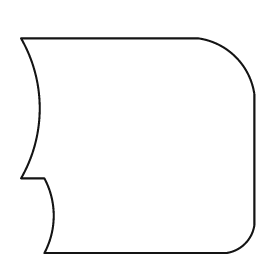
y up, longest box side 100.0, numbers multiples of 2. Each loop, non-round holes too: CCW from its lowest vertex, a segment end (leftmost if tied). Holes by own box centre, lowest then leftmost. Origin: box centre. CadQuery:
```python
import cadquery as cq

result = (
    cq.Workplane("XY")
    .moveTo(-40.0, -46.0)
    .lineTo(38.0, -46.0)
    .threePointArc((46.0, -42.0), (50.0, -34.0))
    .lineTo(50.0, 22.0)
    .threePointArc((42.0, 38.0), (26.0, 46.0))
    .lineTo(-50.0, 46.0)
    .threePointArc((-42.0, 16.0), (-50.0, -14.0))
    .lineTo(-40.0, -14.0)
    .threePointArc((-36.0, -30.0), (-40.0, -46.0))
    .close()
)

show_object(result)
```